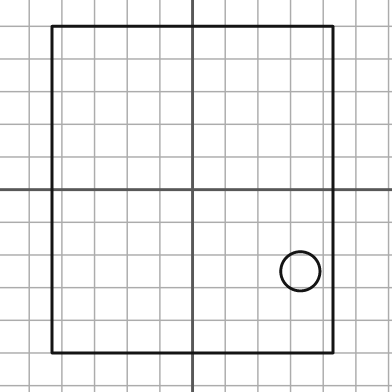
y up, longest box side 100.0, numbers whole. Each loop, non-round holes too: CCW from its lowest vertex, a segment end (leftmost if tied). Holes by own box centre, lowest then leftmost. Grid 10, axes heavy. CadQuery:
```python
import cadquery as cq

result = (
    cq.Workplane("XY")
    .moveTo(-43.0, -50.0)
    .lineTo(43.0, -50.0)
    .lineTo(43.0, 50.0)
    .lineTo(-43.0, 50.0)
    .close()
    .moveTo(33.0, -25.0)
    .circle(6.0)
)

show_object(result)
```